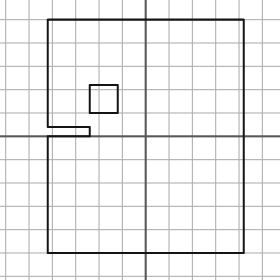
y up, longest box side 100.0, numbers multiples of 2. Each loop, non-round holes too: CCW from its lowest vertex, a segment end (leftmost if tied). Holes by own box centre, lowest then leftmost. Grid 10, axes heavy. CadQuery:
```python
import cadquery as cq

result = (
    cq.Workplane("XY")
    .moveTo(-42.0, -50.0)
    .lineTo(42.0, -50.0)
    .lineTo(42.0, 50.0)
    .lineTo(-42.0, 50.0)
    .lineTo(-42.0, 4.0)
    .lineTo(-24.0, 4.0)
    .lineTo(-24.0, 0.0)
    .lineTo(-42.0, 0.0)
    .close()
    .moveTo(-24.0, 10.0)
    .lineTo(-12.0, 10.0)
    .lineTo(-12.0, 22.0)
    .lineTo(-24.0, 22.0)
    .close()
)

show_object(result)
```